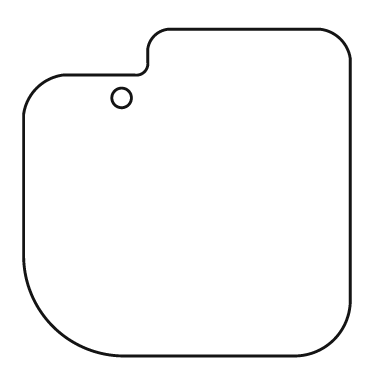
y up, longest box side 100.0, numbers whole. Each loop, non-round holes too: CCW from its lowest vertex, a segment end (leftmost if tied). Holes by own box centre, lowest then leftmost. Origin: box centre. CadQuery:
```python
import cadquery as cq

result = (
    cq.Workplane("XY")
    .moveTo(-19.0, -50.0)
    .lineTo(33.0, -50.0)
    .threePointArc((45.0, -45.0), (50.0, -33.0))
    .lineTo(50.0, 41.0)
    .threePointArc((47.0, 47.0), (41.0, 50.0))
    .lineTo(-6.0, 50.0)
    .threePointArc((-10.0, 48.0), (-12.0, 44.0))
    .lineTo(-12.0, 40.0)
    .threePointArc((-13.0, 37.0), (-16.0, 36.0))
    .lineTo(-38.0, 36.0)
    .threePointArc((-46.0, 32.0), (-50.0, 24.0))
    .lineTo(-50.0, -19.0)
    .threePointArc((-41.0, -41.0), (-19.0, -50.0))
    .close()
    .moveTo(-20.0, 29.0)
    .circle(3.0)
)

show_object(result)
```